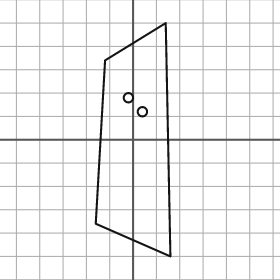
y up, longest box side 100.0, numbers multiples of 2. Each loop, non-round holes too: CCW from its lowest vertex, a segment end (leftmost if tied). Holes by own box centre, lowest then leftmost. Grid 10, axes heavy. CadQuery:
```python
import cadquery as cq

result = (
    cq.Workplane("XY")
    .moveTo(16.0, -50.0)
    .lineTo(14.0, 50.0)
    .lineTo(-12.0, 34.0)
    .lineTo(-16.0, -36.0)
    .close()
    .moveTo(4.0, 12.0)
    .circle(2.0)
    .moveTo(-2.0, 18.0)
    .circle(2.0)
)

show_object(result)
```